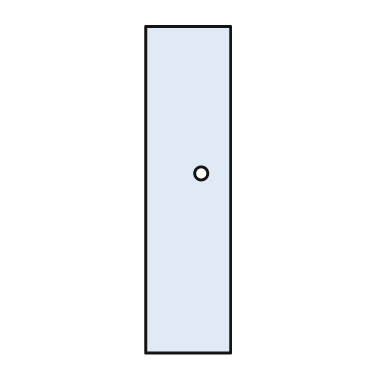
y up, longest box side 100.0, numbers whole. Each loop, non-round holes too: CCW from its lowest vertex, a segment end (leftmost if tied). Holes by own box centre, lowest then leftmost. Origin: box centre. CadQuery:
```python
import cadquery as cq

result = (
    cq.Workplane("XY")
    .moveTo(-13.0, -50.0)
    .lineTo(13.0, -50.0)
    .lineTo(13.0, 50.0)
    .lineTo(-13.0, 50.0)
    .close()
    .moveTo(4.0, 5.0)
    .circle(2.0)
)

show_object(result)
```